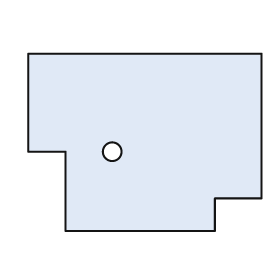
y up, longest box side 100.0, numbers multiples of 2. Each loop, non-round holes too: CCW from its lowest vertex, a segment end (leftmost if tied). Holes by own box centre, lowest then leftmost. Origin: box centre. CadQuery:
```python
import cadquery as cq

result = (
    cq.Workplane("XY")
    .moveTo(-34.0, -38.0)
    .lineTo(30.0, -38.0)
    .lineTo(30.0, -24.0)
    .lineTo(50.0, -24.0)
    .lineTo(50.0, 38.0)
    .lineTo(-50.0, 38.0)
    .lineTo(-50.0, -4.0)
    .lineTo(-34.0, -4.0)
    .close()
    .moveTo(-14.0, -4.0)
    .circle(4.0)
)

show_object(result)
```